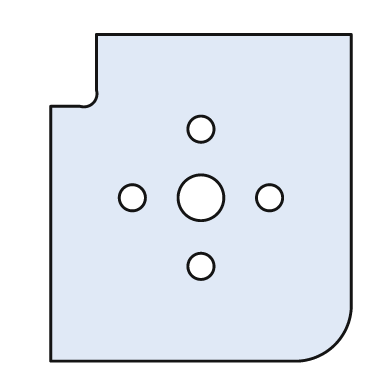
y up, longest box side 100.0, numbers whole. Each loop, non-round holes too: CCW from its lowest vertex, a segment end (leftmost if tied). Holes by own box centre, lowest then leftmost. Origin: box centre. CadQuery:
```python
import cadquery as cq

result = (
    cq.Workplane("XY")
    .moveTo(-46.0, -50.0)
    .lineTo(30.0, -50.0)
    .threePointArc((41.0, -45.0), (46.0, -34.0))
    .lineTo(46.0, 50.0)
    .lineTo(-32.0, 50.0)
    .lineTo(-32.0, 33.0)
    .threePointArc((-33.0, 29.0), (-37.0, 28.0))
    .lineTo(-46.0, 28.0)
    .close()
    .moveTo(0.0, -21.0)
    .circle(4.0)
    .moveTo(-21.0, 0.0)
    .circle(4.0)
    .moveTo(0.0, 0.0)
    .circle(7.0)
    .moveTo(21.0, 0.0)
    .circle(4.0)
    .moveTo(0.0, 21.0)
    .circle(4.0)
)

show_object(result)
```